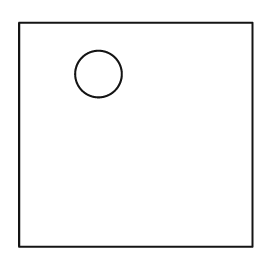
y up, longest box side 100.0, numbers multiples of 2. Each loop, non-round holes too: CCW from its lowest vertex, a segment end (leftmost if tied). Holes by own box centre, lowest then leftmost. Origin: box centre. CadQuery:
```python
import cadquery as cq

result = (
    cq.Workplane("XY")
    .moveTo(-50.0, -48.0)
    .lineTo(50.0, -48.0)
    .lineTo(50.0, 48.0)
    .lineTo(-50.0, 48.0)
    .close()
    .moveTo(-16.0, 26.0)
    .circle(10.0)
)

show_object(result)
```